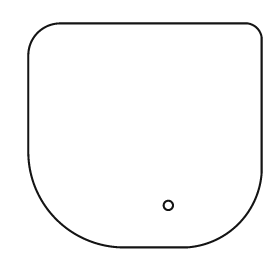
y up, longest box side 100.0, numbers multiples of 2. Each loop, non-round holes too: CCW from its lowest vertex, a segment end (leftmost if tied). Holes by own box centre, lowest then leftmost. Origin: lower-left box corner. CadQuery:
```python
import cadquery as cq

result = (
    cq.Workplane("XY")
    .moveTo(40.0, 0.0)
    .lineTo(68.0, 0.0)
    .threePointArc((90.0, 10.0), (100.0, 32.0))
    .lineTo(100.0, 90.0)
    .threePointArc((98.0, 94.0), (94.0, 96.0))
    .lineTo(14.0, 96.0)
    .threePointArc((4.0, 92.0), (0.0, 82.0))
    .lineTo(0.0, 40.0)
    .threePointArc((12.0, 12.0), (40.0, 0.0))
    .close()
    .moveTo(60.0, 18.0)
    .circle(2.0)
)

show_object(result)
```